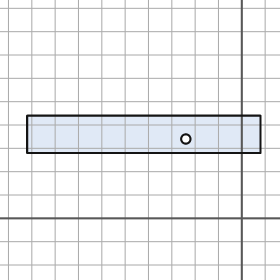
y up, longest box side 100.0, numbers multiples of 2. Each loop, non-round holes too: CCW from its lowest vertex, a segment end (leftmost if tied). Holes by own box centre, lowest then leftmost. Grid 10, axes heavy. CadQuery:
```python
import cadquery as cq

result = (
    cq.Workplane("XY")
    .moveTo(-92.0, 28.0)
    .lineTo(8.0, 28.0)
    .lineTo(8.0, 44.0)
    .lineTo(-92.0, 44.0)
    .close()
    .moveTo(-24.0, 34.0)
    .circle(2.0)
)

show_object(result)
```